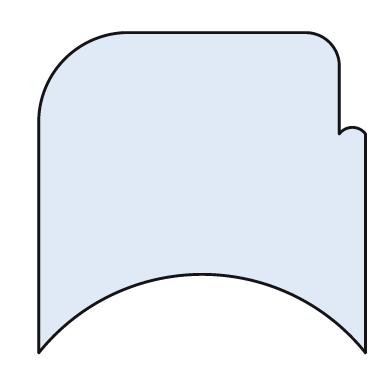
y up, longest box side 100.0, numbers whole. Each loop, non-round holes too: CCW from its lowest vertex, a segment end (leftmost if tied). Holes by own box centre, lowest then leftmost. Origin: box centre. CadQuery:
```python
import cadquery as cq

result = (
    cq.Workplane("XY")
    .moveTo(-50.0, -49.0)
    .threePointArc((0.0, -25.0), (50.0, -49.0))
    .lineTo(50.0, 18.0)
    .threePointArc((46.0, 20.0), (42.0, 18.0))
    .lineTo(42.0, 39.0)
    .threePointArc((39.0, 46.0), (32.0, 49.0))
    .lineTo(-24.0, 49.0)
    .threePointArc((-42.0, 41.0), (-50.0, 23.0))
    .close()
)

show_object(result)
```